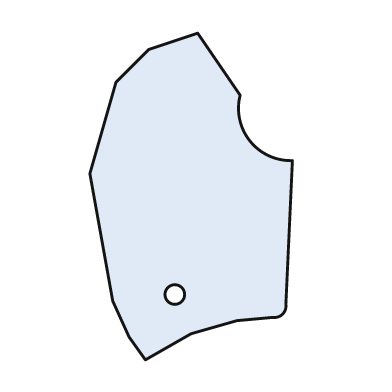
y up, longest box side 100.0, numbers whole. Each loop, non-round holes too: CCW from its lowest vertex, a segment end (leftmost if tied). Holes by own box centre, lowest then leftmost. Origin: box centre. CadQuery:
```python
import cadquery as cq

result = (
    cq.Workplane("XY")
    .moveTo(-14.0, -50.0)
    .lineTo(0.0, -42.0)
    .lineTo(14.0, -38.0)
    .lineTo(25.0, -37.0)
    .threePointArc((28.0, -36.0), (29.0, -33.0))
    .lineTo(31.0, 11.0)
    .threePointArc((18.0, 17.0), (15.0, 31.0))
    .lineTo(2.0, 50.0)
    .lineTo(-13.0, 45.0)
    .lineTo(-23.0, 35.0)
    .lineTo(-31.0, 7.0)
    .lineTo(-24.0, -32.0)
    .lineTo(-19.0, -43.0)
    .close()
    .moveTo(-5.0, -30.0)
    .circle(3.0)
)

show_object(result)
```